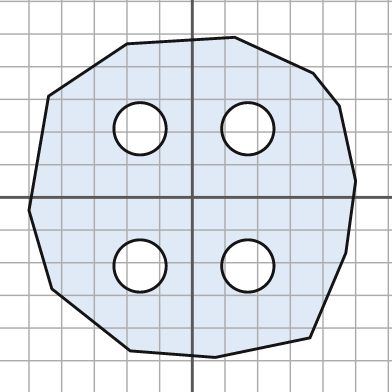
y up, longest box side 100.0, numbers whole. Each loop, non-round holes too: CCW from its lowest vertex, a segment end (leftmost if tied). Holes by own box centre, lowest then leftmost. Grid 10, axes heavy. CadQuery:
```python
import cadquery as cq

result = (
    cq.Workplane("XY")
    .moveTo(7.0, -49.0)
    .lineTo(36.0, -43.0)
    .lineTo(47.0, -17.0)
    .lineTo(50.0, 5.0)
    .lineTo(45.0, 28.0)
    .lineTo(37.0, 38.0)
    .lineTo(13.0, 49.0)
    .lineTo(-20.0, 47.0)
    .lineTo(-44.0, 31.0)
    .lineTo(-50.0, -4.0)
    .lineTo(-43.0, -28.0)
    .lineTo(-19.0, -47.0)
    .close()
    .moveTo(-16.0, -21.0)
    .circle(8.0)
    .moveTo(17.0, -21.0)
    .circle(8.0)
    .moveTo(-16.0, 21.0)
    .circle(8.0)
    .moveTo(17.0, 21.0)
    .circle(8.0)
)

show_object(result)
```